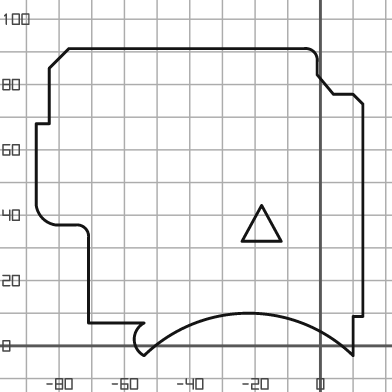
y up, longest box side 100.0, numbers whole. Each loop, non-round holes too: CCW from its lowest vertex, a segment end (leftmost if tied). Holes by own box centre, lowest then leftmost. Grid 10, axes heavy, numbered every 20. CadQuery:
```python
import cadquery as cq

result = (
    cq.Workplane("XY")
    .moveTo(-54.0, -3.0)
    .threePointArc((-22.0, 10.0), (10.0, -3.0))
    .lineTo(10.0, 9.0)
    .lineTo(13.0, 9.0)
    .lineTo(13.0, 74.0)
    .lineTo(10.0, 77.0)
    .lineTo(4.0, 77.0)
    .lineTo(-1.0, 83.0)
    .lineTo(-1.0, 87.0)
    .threePointArc((-2.0, 90.0), (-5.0, 91.0))
    .lineTo(-77.0, 91.0)
    .lineTo(-83.0, 85.0)
    .lineTo(-83.0, 68.0)
    .lineTo(-87.0, 68.0)
    .lineTo(-87.0, 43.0)
    .threePointArc((-85.0, 39.0), (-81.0, 37.0))
    .lineTo(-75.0, 37.0)
    .threePointArc((-72.0, 36.0), (-71.0, 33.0))
    .lineTo(-71.0, 7.0)
    .lineTo(-54.0, 7.0)
    .threePointArc((-57.0, 2.0), (-54.0, -3.0))
    .close()
    .moveTo(-24.0, 32.0)
    .lineTo(-12.0, 32.0)
    .lineTo(-18.0, 43.0)
    .close()
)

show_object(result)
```